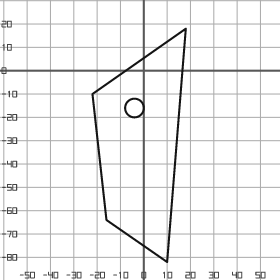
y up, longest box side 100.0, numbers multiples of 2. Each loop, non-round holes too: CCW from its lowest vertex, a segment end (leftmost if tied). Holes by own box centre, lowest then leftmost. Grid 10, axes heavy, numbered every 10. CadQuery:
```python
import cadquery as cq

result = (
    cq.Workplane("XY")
    .moveTo(10.0, -82.0)
    .lineTo(18.0, 18.0)
    .lineTo(-22.0, -10.0)
    .lineTo(-16.0, -64.0)
    .close()
    .moveTo(-4.0, -16.0)
    .circle(4.0)
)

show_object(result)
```